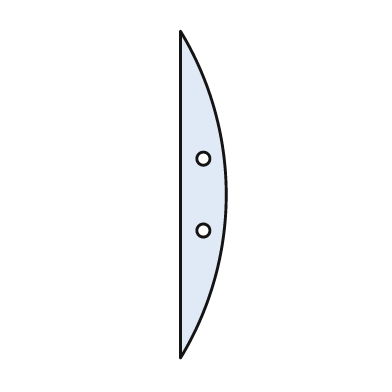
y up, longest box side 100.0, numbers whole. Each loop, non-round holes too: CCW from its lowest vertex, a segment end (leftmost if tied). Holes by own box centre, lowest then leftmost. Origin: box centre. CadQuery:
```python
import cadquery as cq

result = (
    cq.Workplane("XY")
    .moveTo(-7.0, -50.0)
    .threePointArc((7.0, 0.0), (-7.0, 50.0))
    .close()
    .moveTo(0.0, -11.0)
    .circle(2.0)
    .moveTo(0.0, 11.0)
    .circle(2.0)
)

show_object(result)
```